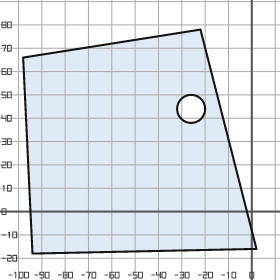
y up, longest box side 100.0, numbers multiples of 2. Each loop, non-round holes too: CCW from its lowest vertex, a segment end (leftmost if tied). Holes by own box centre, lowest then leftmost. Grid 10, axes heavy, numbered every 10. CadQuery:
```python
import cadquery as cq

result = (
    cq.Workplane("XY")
    .moveTo(-94.0, -18.0)
    .lineTo(2.0, -16.0)
    .lineTo(-22.0, 78.0)
    .lineTo(-98.0, 66.0)
    .close()
    .moveTo(-26.0, 44.0)
    .circle(6.0)
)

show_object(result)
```